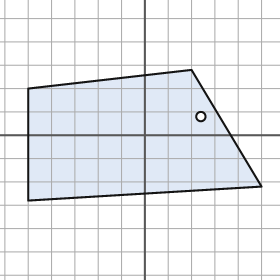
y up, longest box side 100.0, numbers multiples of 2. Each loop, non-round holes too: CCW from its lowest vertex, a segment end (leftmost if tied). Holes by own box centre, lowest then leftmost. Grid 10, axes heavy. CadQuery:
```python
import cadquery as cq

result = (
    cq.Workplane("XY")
    .moveTo(-50.0, -28.0)
    .lineTo(50.0, -22.0)
    .lineTo(20.0, 28.0)
    .lineTo(-50.0, 20.0)
    .close()
    .moveTo(24.0, 8.0)
    .circle(2.0)
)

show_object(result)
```